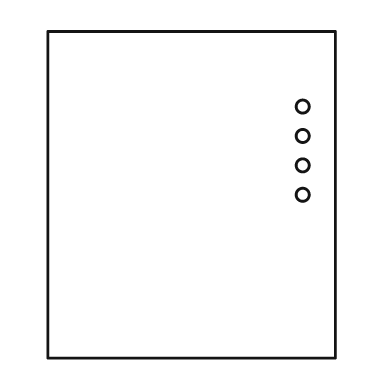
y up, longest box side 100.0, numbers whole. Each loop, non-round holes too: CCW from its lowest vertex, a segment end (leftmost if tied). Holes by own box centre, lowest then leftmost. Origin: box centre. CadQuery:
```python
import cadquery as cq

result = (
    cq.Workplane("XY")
    .moveTo(-44.0, -50.0)
    .lineTo(44.0, -50.0)
    .lineTo(44.0, 50.0)
    .lineTo(-44.0, 50.0)
    .close()
    .moveTo(34.0, 0.0)
    .circle(2.0)
    .moveTo(34.0, 9.0)
    .circle(2.0)
    .moveTo(34.0, 18.0)
    .circle(2.0)
    .moveTo(34.0, 27.0)
    .circle(2.0)
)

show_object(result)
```